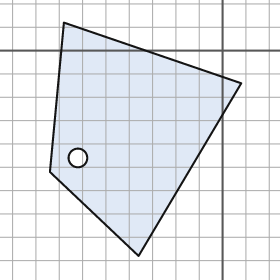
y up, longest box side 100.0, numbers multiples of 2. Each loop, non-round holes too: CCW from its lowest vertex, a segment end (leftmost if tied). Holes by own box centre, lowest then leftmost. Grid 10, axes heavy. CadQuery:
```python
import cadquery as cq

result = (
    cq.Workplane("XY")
    .moveTo(-36.0, -88.0)
    .lineTo(8.0, -14.0)
    .lineTo(-68.0, 12.0)
    .lineTo(-74.0, -52.0)
    .close()
    .moveTo(-62.0, -46.0)
    .circle(4.0)
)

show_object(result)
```